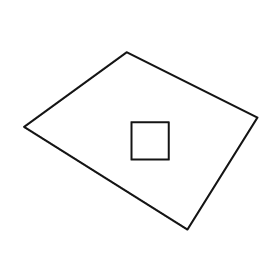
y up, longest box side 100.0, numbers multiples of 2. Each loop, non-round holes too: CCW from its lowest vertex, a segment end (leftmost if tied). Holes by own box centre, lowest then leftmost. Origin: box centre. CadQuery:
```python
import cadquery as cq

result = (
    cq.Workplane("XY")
    .moveTo(20.0, -38.0)
    .lineTo(50.0, 10.0)
    .lineTo(-6.0, 38.0)
    .lineTo(-50.0, 6.0)
    .close()
    .moveTo(-4.0, -8.0)
    .lineTo(12.0, -8.0)
    .lineTo(12.0, 8.0)
    .lineTo(-4.0, 8.0)
    .close()
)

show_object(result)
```